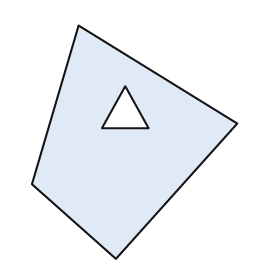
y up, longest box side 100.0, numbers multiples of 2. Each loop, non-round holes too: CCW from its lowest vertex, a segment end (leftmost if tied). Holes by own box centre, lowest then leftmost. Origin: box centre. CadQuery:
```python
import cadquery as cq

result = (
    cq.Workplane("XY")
    .moveTo(-8.0, -50.0)
    .lineTo(44.0, 8.0)
    .lineTo(-24.0, 50.0)
    .lineTo(-44.0, -18.0)
    .close()
    .moveTo(-14.0, 6.0)
    .lineTo(6.0, 6.0)
    .lineTo(-4.0, 24.0)
    .close()
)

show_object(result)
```